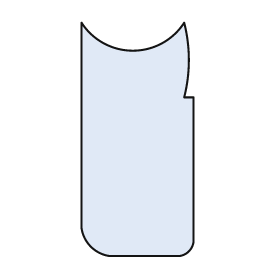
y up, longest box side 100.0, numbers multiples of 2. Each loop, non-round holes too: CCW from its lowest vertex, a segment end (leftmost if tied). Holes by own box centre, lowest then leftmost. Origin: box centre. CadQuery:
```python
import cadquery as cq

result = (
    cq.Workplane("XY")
    .moveTo(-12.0, -50.0)
    .lineTo(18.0, -50.0)
    .threePointArc((22.0, -48.0), (24.0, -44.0))
    .lineTo(24.0, 18.0)
    .lineTo(20.0, 18.0)
    .threePointArc((22.0, 34.0), (20.0, 50.0))
    .threePointArc((-2.0, 38.0), (-24.0, 50.0))
    .lineTo(-24.0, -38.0)
    .threePointArc((-20.0, -46.0), (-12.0, -50.0))
    .close()
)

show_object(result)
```